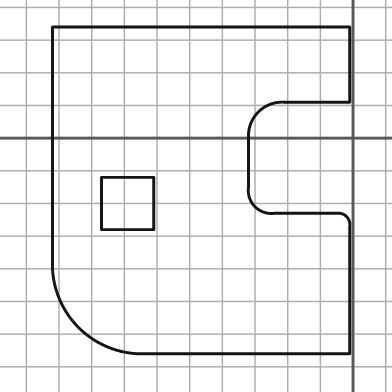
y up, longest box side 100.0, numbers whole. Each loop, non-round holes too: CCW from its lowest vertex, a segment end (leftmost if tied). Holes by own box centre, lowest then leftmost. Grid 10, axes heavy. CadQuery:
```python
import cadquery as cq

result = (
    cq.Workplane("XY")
    .moveTo(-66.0, -66.0)
    .lineTo(-1.0, -66.0)
    .lineTo(-1.0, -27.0)
    .threePointArc((-2.0, -24.0), (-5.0, -23.0))
    .lineTo(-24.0, -23.0)
    .threePointArc((-30.0, -21.0), (-32.0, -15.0))
    .lineTo(-32.0, 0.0)
    .threePointArc((-29.0, 8.0), (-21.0, 11.0))
    .lineTo(-1.0, 11.0)
    .lineTo(-1.0, 34.0)
    .lineTo(-92.0, 34.0)
    .lineTo(-92.0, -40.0)
    .threePointArc((-84.0, -58.0), (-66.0, -66.0))
    .close()
    .moveTo(-77.0, -28.0)
    .lineTo(-61.0, -28.0)
    .lineTo(-61.0, -12.0)
    .lineTo(-77.0, -12.0)
    .close()
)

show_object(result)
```